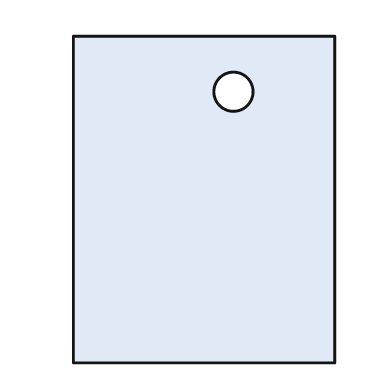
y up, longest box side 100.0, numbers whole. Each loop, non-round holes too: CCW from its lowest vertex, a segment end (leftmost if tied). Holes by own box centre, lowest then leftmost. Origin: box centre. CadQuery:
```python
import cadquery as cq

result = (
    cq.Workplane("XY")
    .moveTo(-40.0, -50.0)
    .lineTo(40.0, -50.0)
    .lineTo(40.0, 50.0)
    .lineTo(-40.0, 50.0)
    .close()
    .moveTo(9.0, 33.0)
    .circle(6.0)
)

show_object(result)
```